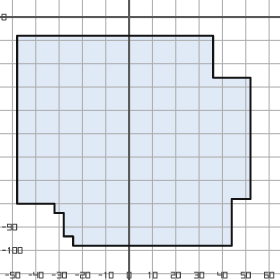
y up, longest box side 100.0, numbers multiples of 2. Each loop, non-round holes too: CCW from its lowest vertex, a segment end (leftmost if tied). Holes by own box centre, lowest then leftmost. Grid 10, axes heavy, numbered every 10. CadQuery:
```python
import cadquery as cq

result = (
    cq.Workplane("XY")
    .moveTo(-24.0, -98.0)
    .lineTo(44.0, -98.0)
    .lineTo(44.0, -78.0)
    .lineTo(52.0, -78.0)
    .lineTo(52.0, -26.0)
    .lineTo(36.0, -26.0)
    .lineTo(36.0, -8.0)
    .lineTo(-48.0, -8.0)
    .lineTo(-48.0, -80.0)
    .lineTo(-32.0, -80.0)
    .lineTo(-32.0, -84.0)
    .lineTo(-28.0, -84.0)
    .lineTo(-28.0, -94.0)
    .lineTo(-24.0, -94.0)
    .close()
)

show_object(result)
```